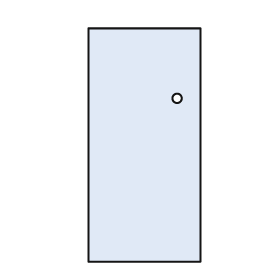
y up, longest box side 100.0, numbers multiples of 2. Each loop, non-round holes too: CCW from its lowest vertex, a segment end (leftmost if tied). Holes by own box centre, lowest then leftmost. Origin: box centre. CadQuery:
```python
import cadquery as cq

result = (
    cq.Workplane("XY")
    .moveTo(-24.0, -50.0)
    .lineTo(24.0, -50.0)
    .lineTo(24.0, 50.0)
    .lineTo(-24.0, 50.0)
    .close()
    .moveTo(14.0, 20.0)
    .circle(2.0)
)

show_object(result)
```